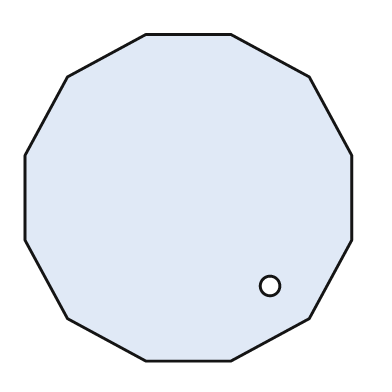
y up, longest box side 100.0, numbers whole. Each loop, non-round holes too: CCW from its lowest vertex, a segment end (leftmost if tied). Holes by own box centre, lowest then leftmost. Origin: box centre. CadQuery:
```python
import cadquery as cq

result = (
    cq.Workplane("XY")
    .moveTo(-13.0, -50.0)
    .lineTo(13.0, -50.0)
    .lineTo(37.0, -37.0)
    .lineTo(50.0, -13.0)
    .lineTo(50.0, 13.0)
    .lineTo(37.0, 37.0)
    .lineTo(13.0, 50.0)
    .lineTo(-13.0, 50.0)
    .lineTo(-37.0, 37.0)
    .lineTo(-50.0, 13.0)
    .lineTo(-50.0, -13.0)
    .lineTo(-37.0, -37.0)
    .close()
    .moveTo(25.0, -27.0)
    .circle(3.0)
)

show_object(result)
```